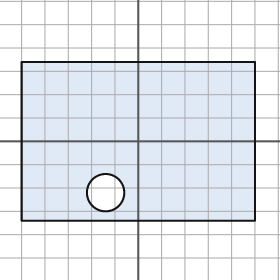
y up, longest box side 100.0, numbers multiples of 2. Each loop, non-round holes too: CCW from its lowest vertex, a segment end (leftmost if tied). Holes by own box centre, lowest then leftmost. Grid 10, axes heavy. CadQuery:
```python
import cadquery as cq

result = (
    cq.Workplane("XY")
    .moveTo(-50.0, -34.0)
    .lineTo(50.0, -34.0)
    .lineTo(50.0, 34.0)
    .lineTo(-50.0, 34.0)
    .close()
    .moveTo(-14.0, -22.0)
    .circle(8.0)
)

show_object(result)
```